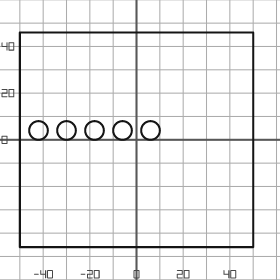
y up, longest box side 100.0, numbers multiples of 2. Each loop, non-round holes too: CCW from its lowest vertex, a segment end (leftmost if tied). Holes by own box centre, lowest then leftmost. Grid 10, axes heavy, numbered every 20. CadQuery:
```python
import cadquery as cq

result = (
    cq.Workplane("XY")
    .moveTo(-50.0, -46.0)
    .lineTo(50.0, -46.0)
    .lineTo(50.0, 46.0)
    .lineTo(-50.0, 46.0)
    .close()
    .moveTo(-42.0, 4.0)
    .circle(4.0)
    .moveTo(-30.0, 4.0)
    .circle(4.0)
    .moveTo(-18.0, 4.0)
    .circle(4.0)
    .moveTo(-6.0, 4.0)
    .circle(4.0)
    .moveTo(6.0, 4.0)
    .circle(4.0)
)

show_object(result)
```